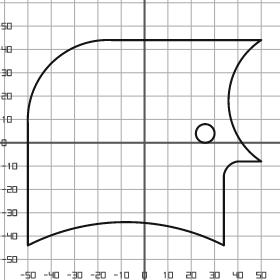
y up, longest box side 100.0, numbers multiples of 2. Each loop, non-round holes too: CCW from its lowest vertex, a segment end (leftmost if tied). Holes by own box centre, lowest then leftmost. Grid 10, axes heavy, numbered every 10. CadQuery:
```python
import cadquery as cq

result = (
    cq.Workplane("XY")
    .moveTo(-50.0, -44.0)
    .threePointArc((-8.0, -34.0), (34.0, -44.0))
    .lineTo(34.0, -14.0)
    .threePointArc((36.0, -10.0), (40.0, -8.0))
    .lineTo(50.0, -8.0)
    .threePointArc((36.0, 18.0), (50.0, 44.0))
    .lineTo(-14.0, 44.0)
    .threePointArc((-40.0, 34.0), (-50.0, 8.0))
    .close()
    .moveTo(26.0, 4.0)
    .circle(4.0)
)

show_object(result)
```